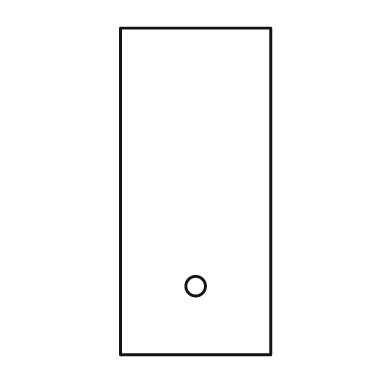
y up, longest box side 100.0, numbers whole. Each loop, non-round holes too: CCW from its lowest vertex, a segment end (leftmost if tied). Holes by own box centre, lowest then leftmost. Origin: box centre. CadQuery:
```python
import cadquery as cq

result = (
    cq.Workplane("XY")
    .moveTo(-23.0, -50.0)
    .lineTo(23.0, -50.0)
    .lineTo(23.0, 50.0)
    .lineTo(-23.0, 50.0)
    .close()
    .moveTo(0.0, -29.0)
    .circle(3.0)
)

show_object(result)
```